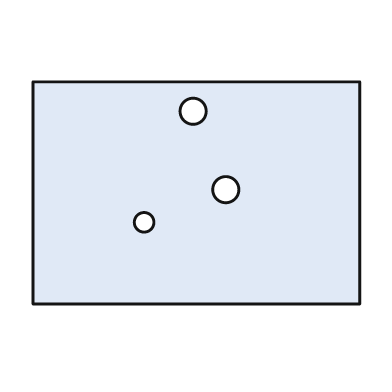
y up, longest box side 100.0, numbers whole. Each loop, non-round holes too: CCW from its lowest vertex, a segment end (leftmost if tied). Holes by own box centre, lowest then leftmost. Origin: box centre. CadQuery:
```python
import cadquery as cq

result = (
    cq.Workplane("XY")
    .moveTo(-50.0, -34.0)
    .lineTo(50.0, -34.0)
    .lineTo(50.0, 34.0)
    .lineTo(-50.0, 34.0)
    .close()
    .moveTo(-16.0, -9.0)
    .circle(3.0)
    .moveTo(9.0, 1.0)
    .circle(4.0)
    .moveTo(-1.0, 25.0)
    .circle(4.0)
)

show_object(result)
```